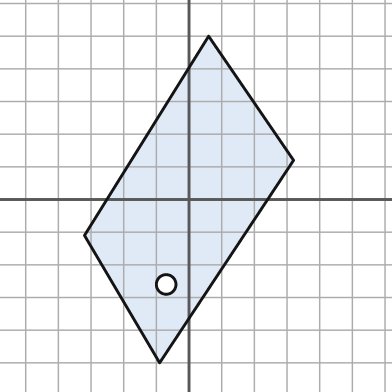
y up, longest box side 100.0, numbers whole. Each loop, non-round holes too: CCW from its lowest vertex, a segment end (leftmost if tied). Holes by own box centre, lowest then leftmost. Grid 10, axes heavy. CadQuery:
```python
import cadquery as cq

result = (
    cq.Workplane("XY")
    .moveTo(-9.0, -50.0)
    .lineTo(32.0, 12.0)
    .lineTo(6.0, 50.0)
    .lineTo(-32.0, -11.0)
    .close()
    .moveTo(-7.0, -26.0)
    .circle(3.0)
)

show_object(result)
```